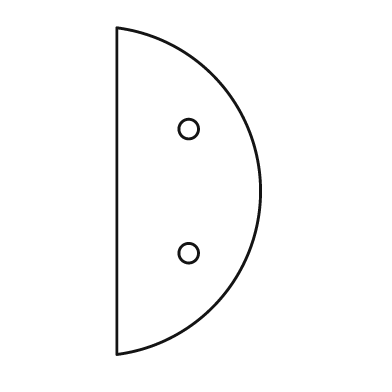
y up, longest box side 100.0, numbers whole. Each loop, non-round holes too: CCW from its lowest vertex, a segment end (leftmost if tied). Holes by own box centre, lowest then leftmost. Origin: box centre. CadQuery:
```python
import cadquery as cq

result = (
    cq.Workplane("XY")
    .moveTo(-22.0, -50.0)
    .threePointArc((22.0, 0.0), (-22.0, 50.0))
    .close()
    .moveTo(0.0, -19.0)
    .circle(3.0)
    .moveTo(0.0, 19.0)
    .circle(3.0)
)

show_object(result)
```